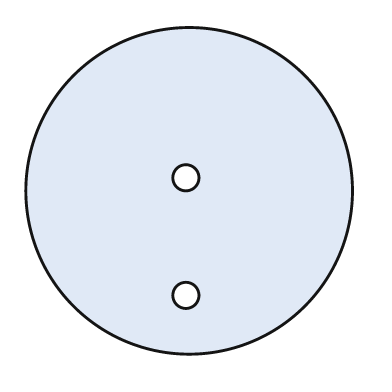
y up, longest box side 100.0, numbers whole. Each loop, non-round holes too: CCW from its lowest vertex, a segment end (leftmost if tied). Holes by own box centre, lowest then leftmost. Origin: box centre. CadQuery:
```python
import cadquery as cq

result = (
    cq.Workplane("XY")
    .moveTo(0.0, 0.0)
    .circle(50.0)
    .moveTo(-1.0, -32.0)
    .circle(4.0)
    .moveTo(-1.0, 4.0)
    .circle(4.0)
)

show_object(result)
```